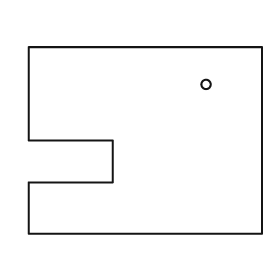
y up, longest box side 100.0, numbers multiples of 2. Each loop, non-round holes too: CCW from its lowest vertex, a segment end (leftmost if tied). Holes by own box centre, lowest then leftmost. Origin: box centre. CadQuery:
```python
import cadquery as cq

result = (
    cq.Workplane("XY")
    .moveTo(-50.0, -40.0)
    .lineTo(50.0, -40.0)
    .lineTo(50.0, 40.0)
    .lineTo(-50.0, 40.0)
    .lineTo(-50.0, 0.0)
    .lineTo(-14.0, 0.0)
    .lineTo(-14.0, -18.0)
    .lineTo(-50.0, -18.0)
    .close()
    .moveTo(26.0, 24.0)
    .circle(2.0)
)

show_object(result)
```